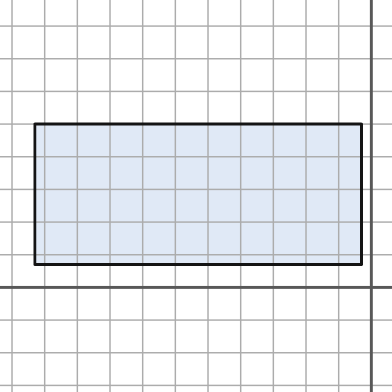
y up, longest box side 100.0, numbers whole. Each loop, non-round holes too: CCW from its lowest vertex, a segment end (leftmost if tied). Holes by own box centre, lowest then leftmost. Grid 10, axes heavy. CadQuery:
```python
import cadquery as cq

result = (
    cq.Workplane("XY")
    .moveTo(-103.0, 7.0)
    .lineTo(-3.0, 7.0)
    .lineTo(-3.0, 50.0)
    .lineTo(-103.0, 50.0)
    .close()
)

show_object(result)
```